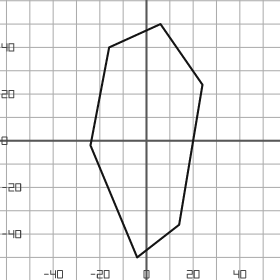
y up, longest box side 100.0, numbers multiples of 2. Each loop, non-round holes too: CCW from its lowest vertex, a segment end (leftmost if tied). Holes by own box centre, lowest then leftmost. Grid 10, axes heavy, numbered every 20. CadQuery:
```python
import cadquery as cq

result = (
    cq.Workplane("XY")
    .moveTo(-4.0, -50.0)
    .lineTo(14.0, -36.0)
    .lineTo(24.0, 24.0)
    .lineTo(6.0, 50.0)
    .lineTo(-16.0, 40.0)
    .lineTo(-24.0, -2.0)
    .close()
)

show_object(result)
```